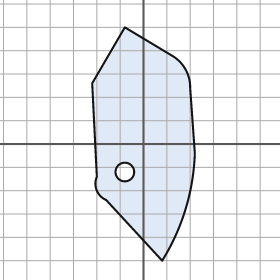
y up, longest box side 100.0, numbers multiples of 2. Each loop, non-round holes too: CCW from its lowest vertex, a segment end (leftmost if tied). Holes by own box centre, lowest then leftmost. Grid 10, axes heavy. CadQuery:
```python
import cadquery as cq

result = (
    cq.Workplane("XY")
    .moveTo(8.0, -50.0)
    .threePointArc((18.0, -28.0), (22.0, -4.0))
    .lineTo(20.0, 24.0)
    .threePointArc((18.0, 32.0), (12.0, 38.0))
    .lineTo(-8.0, 50.0)
    .lineTo(-22.0, 26.0)
    .lineTo(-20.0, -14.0)
    .threePointArc((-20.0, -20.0), (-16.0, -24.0))
    .close()
    .moveTo(-8.0, -12.0)
    .circle(4.0)
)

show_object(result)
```